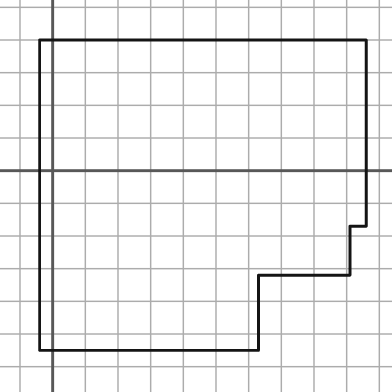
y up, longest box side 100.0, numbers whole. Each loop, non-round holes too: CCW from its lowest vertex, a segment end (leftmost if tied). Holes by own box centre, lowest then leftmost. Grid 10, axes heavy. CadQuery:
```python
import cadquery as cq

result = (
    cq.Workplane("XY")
    .moveTo(-4.0, -55.0)
    .lineTo(63.0, -55.0)
    .lineTo(63.0, -32.0)
    .lineTo(91.0, -32.0)
    .lineTo(91.0, -17.0)
    .lineTo(96.0, -17.0)
    .lineTo(96.0, 40.0)
    .lineTo(-4.0, 40.0)
    .close()
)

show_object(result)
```